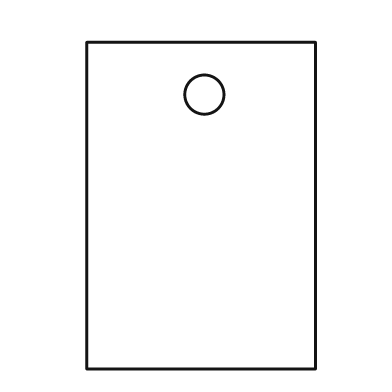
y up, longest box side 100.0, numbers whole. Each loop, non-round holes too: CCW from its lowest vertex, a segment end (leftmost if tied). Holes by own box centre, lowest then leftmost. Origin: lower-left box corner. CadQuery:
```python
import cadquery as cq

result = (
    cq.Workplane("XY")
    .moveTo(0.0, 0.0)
    .lineTo(70.0, 0.0)
    .lineTo(70.0, 100.0)
    .lineTo(0.0, 100.0)
    .close()
    .moveTo(36.0, 84.0)
    .circle(6.0)
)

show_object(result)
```